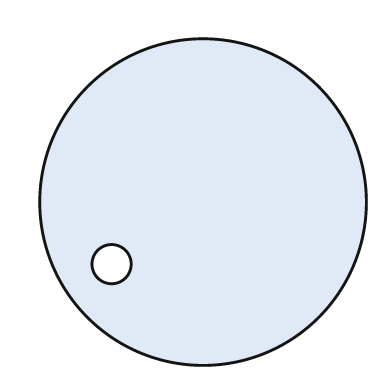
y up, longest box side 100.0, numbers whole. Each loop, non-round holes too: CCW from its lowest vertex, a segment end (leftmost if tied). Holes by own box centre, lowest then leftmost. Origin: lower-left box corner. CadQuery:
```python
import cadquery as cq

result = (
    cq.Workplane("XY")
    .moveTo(50.0, 50.0)
    .circle(50.0)
    .moveTo(22.0, 31.0)
    .circle(6.0)
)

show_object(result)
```